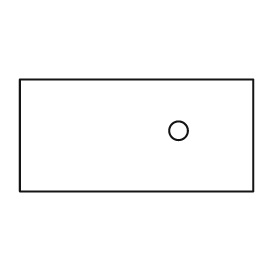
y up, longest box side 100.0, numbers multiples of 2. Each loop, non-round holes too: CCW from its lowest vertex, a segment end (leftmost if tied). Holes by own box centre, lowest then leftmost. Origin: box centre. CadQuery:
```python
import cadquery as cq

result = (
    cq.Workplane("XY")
    .moveTo(-50.0, -24.0)
    .lineTo(50.0, -24.0)
    .lineTo(50.0, 24.0)
    .lineTo(-50.0, 24.0)
    .close()
    .moveTo(18.0, 2.0)
    .circle(4.0)
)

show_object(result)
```